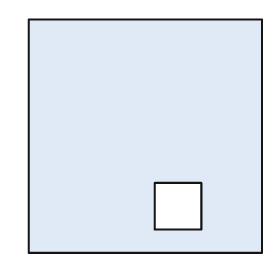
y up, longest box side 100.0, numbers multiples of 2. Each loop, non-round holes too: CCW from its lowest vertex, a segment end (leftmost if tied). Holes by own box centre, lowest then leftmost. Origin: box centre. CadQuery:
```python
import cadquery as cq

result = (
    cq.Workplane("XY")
    .moveTo(-50.0, -50.0)
    .lineTo(50.0, -50.0)
    .lineTo(50.0, 50.0)
    .lineTo(-50.0, 50.0)
    .close()
    .moveTo(4.0, -40.0)
    .lineTo(24.0, -40.0)
    .lineTo(24.0, -20.0)
    .lineTo(4.0, -20.0)
    .close()
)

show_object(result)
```